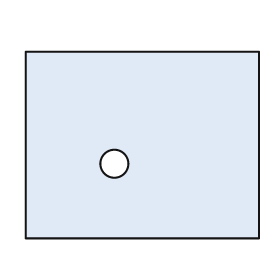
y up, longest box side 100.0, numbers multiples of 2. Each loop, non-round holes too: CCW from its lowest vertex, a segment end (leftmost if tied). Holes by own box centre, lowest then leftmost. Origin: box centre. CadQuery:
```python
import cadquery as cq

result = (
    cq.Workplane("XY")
    .moveTo(-50.0, -40.0)
    .lineTo(50.0, -40.0)
    .lineTo(50.0, 40.0)
    .lineTo(-50.0, 40.0)
    .close()
    .moveTo(-12.0, -8.0)
    .circle(6.0)
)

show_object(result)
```